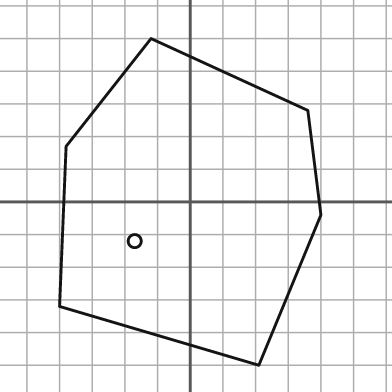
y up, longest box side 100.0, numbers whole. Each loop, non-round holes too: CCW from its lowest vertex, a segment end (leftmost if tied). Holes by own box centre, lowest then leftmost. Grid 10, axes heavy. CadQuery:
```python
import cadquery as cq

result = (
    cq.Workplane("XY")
    .moveTo(21.0, -50.0)
    .lineTo(40.0, -4.0)
    .lineTo(36.0, 28.0)
    .lineTo(-12.0, 50.0)
    .lineTo(-38.0, 17.0)
    .lineTo(-40.0, -32.0)
    .close()
    .moveTo(-17.0, -12.0)
    .circle(2.0)
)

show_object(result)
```